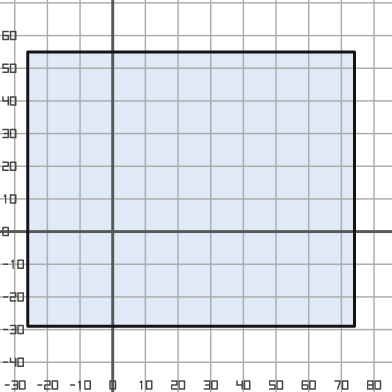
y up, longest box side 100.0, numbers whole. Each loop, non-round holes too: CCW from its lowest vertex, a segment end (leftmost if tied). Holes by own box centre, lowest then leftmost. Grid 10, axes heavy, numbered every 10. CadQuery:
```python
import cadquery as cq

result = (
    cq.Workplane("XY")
    .moveTo(-26.0, -29.0)
    .lineTo(74.0, -29.0)
    .lineTo(74.0, 55.0)
    .lineTo(-26.0, 55.0)
    .close()
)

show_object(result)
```